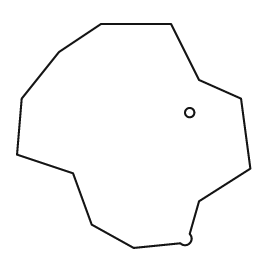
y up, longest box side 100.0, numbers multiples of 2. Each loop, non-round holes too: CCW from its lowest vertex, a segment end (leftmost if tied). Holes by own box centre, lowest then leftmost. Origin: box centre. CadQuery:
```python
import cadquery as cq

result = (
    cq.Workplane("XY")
    .moveTo(0.0, -48.0)
    .lineTo(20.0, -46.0)
    .threePointArc((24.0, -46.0), (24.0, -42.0))
    .lineTo(28.0, -28.0)
    .lineTo(50.0, -14.0)
    .lineTo(46.0, 16.0)
    .lineTo(28.0, 24.0)
    .lineTo(16.0, 48.0)
    .lineTo(-14.0, 48.0)
    .lineTo(-32.0, 36.0)
    .lineTo(-48.0, 16.0)
    .lineTo(-50.0, -8.0)
    .lineTo(-26.0, -16.0)
    .lineTo(-18.0, -38.0)
    .close()
    .moveTo(24.0, 10.0)
    .circle(2.0)
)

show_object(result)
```